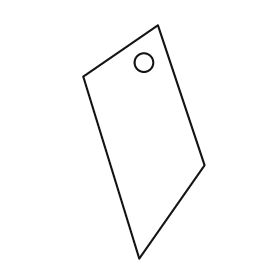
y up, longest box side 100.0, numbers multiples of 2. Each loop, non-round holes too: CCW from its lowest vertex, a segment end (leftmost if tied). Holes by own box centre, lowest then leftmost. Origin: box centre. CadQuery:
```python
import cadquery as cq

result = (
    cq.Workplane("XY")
    .moveTo(-2.0, -50.0)
    .lineTo(26.0, -10.0)
    .lineTo(6.0, 50.0)
    .lineTo(-26.0, 28.0)
    .close()
    .moveTo(0.0, 34.0)
    .circle(4.0)
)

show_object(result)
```